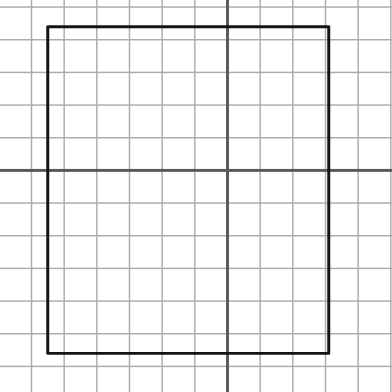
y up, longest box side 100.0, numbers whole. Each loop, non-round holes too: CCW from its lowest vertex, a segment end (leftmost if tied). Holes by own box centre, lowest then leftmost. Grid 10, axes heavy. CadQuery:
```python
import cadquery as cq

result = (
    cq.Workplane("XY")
    .moveTo(-55.0, -56.0)
    .lineTo(31.0, -56.0)
    .lineTo(31.0, 44.0)
    .lineTo(-55.0, 44.0)
    .close()
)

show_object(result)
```